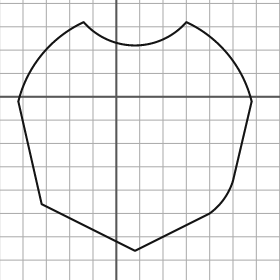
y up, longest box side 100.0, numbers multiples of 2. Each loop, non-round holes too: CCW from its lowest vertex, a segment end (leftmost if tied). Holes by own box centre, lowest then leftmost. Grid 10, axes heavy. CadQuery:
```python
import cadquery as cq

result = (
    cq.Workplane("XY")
    .moveTo(8.0, -66.0)
    .lineTo(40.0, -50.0)
    .threePointArc((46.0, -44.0), (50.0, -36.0))
    .lineTo(58.0, -2.0)
    .threePointArc((48.0, 18.0), (30.0, 32.0))
    .threePointArc((8.0, 22.0), (-14.0, 32.0))
    .threePointArc((-32.0, 18.0), (-42.0, -2.0))
    .lineTo(-32.0, -46.0)
    .close()
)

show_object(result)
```